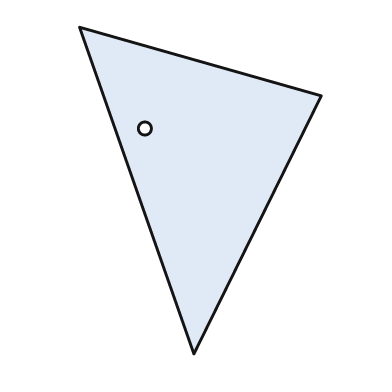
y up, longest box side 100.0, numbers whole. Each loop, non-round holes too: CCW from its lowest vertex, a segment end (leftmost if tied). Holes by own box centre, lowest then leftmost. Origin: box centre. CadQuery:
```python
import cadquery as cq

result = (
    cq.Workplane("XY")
    .moveTo(-2.0, -50.0)
    .lineTo(37.0, 29.0)
    .lineTo(-37.0, 50.0)
    .close()
    .moveTo(-17.0, 19.0)
    .circle(2.0)
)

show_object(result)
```